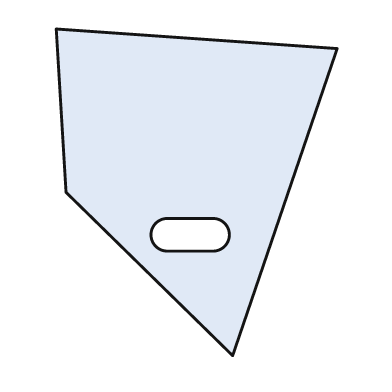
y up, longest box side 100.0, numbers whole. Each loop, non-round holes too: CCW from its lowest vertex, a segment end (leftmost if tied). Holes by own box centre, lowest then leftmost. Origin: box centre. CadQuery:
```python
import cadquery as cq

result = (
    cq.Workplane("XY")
    .moveTo(11.0, -50.0)
    .lineTo(43.0, 44.0)
    .lineTo(-43.0, 50.0)
    .lineTo(-40.0, 0.0)
    .close()
    .moveTo(-9.0, -18.0)
    .lineTo(5.0, -18.0)
    .threePointArc((10.0, -13.0), (5.0, -8.0))
    .lineTo(-9.0, -8.0)
    .threePointArc((-14.0, -13.0), (-9.0, -18.0))
    .close()
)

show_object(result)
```